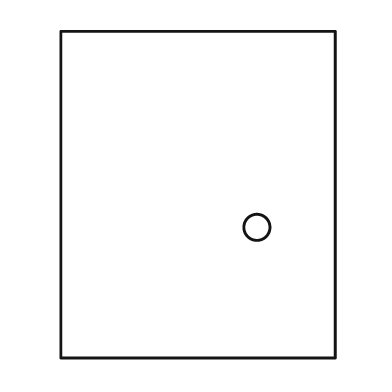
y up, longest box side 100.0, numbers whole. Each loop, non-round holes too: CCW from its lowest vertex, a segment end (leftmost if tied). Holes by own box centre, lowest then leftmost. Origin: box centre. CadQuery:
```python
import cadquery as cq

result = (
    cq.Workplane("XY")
    .moveTo(-42.0, -50.0)
    .lineTo(42.0, -50.0)
    .lineTo(42.0, 50.0)
    .lineTo(-42.0, 50.0)
    .close()
    .moveTo(18.0, -10.0)
    .circle(4.0)
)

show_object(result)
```